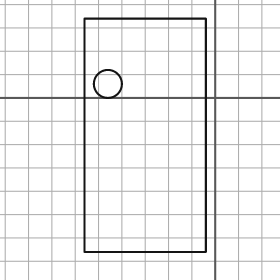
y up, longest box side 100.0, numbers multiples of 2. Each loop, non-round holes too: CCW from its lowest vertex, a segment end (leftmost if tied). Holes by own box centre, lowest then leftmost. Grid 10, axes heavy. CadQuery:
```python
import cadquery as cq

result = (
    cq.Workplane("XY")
    .moveTo(-56.0, -66.0)
    .lineTo(-4.0, -66.0)
    .lineTo(-4.0, 34.0)
    .lineTo(-56.0, 34.0)
    .close()
    .moveTo(-46.0, 6.0)
    .circle(6.0)
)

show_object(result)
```